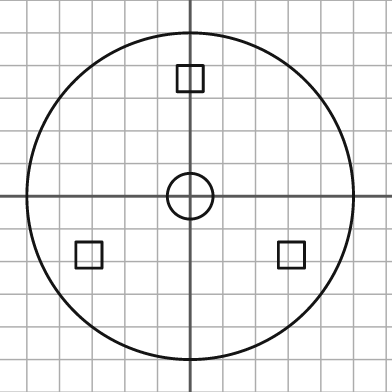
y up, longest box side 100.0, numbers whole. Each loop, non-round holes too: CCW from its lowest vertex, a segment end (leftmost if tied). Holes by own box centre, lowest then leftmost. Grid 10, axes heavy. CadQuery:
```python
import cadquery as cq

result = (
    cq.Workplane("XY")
    .moveTo(0.0, 0.0)
    .circle(50.0)
    .moveTo(-35.0, -22.0)
    .lineTo(-27.0, -22.0)
    .lineTo(-27.0, -14.0)
    .lineTo(-35.0, -14.0)
    .close()
    .moveTo(27.0, -22.0)
    .lineTo(35.0, -22.0)
    .lineTo(35.0, -14.0)
    .lineTo(27.0, -14.0)
    .close()
    .moveTo(0.0, 0.0)
    .circle(7.0)
    .moveTo(-4.0, 32.0)
    .lineTo(4.0, 32.0)
    .lineTo(4.0, 40.0)
    .lineTo(-4.0, 40.0)
    .close()
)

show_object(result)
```